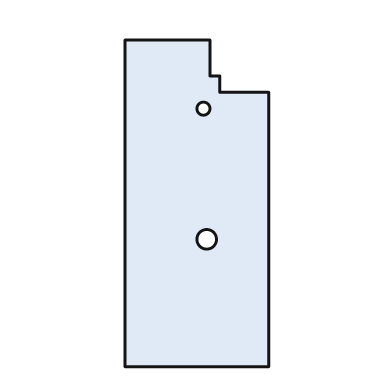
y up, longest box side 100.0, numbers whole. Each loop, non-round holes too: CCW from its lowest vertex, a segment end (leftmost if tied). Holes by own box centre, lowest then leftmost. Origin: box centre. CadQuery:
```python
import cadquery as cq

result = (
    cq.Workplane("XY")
    .moveTo(-22.0, -50.0)
    .lineTo(22.0, -50.0)
    .lineTo(22.0, 34.0)
    .lineTo(7.0, 34.0)
    .lineTo(7.0, 39.0)
    .lineTo(4.0, 39.0)
    .lineTo(4.0, 50.0)
    .lineTo(-22.0, 50.0)
    .close()
    .moveTo(3.0, -11.0)
    .circle(3.0)
    .moveTo(2.0, 29.0)
    .circle(2.0)
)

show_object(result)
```